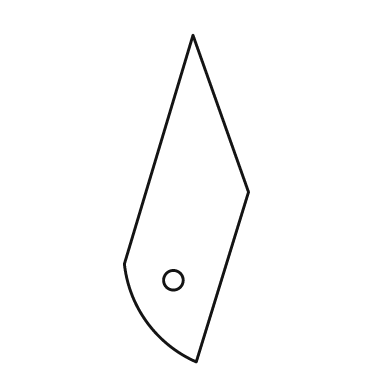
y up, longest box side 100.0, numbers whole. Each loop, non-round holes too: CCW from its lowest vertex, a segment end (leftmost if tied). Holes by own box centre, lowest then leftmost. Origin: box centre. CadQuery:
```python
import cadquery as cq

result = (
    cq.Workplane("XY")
    .moveTo(3.0, -50.0)
    .lineTo(19.0, 2.0)
    .lineTo(2.0, 50.0)
    .lineTo(-19.0, -20.0)
    .threePointArc((-12.0, -38.0), (3.0, -50.0))
    .close()
    .moveTo(-4.0, -25.0)
    .circle(3.0)
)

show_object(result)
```